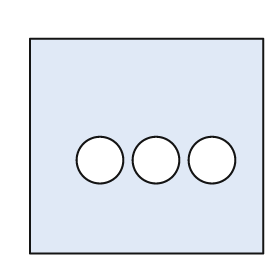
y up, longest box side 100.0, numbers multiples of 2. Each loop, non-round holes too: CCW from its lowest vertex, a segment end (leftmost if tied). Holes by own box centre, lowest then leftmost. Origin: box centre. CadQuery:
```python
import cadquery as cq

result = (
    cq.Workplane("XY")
    .moveTo(-50.0, -46.0)
    .lineTo(50.0, -46.0)
    .lineTo(50.0, 46.0)
    .lineTo(-50.0, 46.0)
    .close()
    .moveTo(-20.0, -6.0)
    .circle(10.0)
    .moveTo(4.0, -6.0)
    .circle(10.0)
    .moveTo(28.0, -6.0)
    .circle(10.0)
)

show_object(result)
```